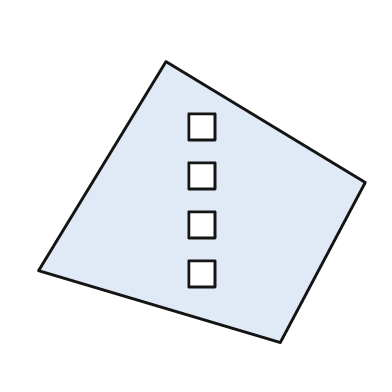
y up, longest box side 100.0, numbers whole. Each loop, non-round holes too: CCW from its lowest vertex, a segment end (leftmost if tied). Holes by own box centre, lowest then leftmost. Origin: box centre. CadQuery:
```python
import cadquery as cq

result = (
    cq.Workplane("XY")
    .moveTo(24.0, -43.0)
    .lineTo(50.0, 6.0)
    .lineTo(-11.0, 43.0)
    .lineTo(-50.0, -21.0)
    .close()
    .moveTo(-4.0, -26.0)
    .lineTo(4.0, -26.0)
    .lineTo(4.0, -18.0)
    .lineTo(-4.0, -18.0)
    .close()
    .moveTo(-4.0, -11.0)
    .lineTo(4.0, -11.0)
    .lineTo(4.0, -3.0)
    .lineTo(-4.0, -3.0)
    .close()
    .moveTo(-4.0, 4.0)
    .lineTo(4.0, 4.0)
    .lineTo(4.0, 12.0)
    .lineTo(-4.0, 12.0)
    .close()
    .moveTo(-4.0, 19.0)
    .lineTo(4.0, 19.0)
    .lineTo(4.0, 27.0)
    .lineTo(-4.0, 27.0)
    .close()
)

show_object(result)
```